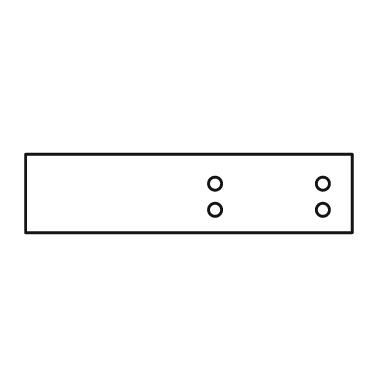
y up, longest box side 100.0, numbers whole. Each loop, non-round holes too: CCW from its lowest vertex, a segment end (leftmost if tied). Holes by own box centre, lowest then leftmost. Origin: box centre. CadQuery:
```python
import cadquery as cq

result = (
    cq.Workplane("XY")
    .moveTo(-50.0, -12.0)
    .lineTo(50.0, -12.0)
    .lineTo(50.0, 12.0)
    .lineTo(-50.0, 12.0)
    .close()
    .moveTo(8.0, -5.0)
    .circle(2.0)
    .moveTo(41.0, -5.0)
    .circle(2.0)
    .moveTo(8.0, 3.0)
    .circle(2.0)
    .moveTo(41.0, 3.0)
    .circle(2.0)
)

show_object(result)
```